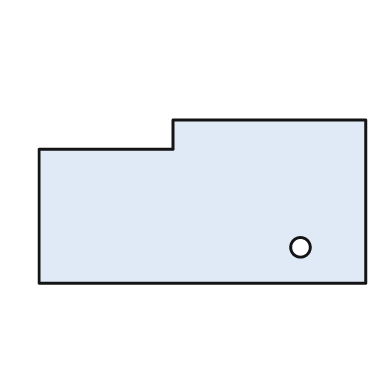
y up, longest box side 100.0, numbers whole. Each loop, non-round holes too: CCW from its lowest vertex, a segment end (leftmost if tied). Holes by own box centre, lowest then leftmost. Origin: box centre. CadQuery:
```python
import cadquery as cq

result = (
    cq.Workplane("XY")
    .moveTo(-50.0, -25.0)
    .lineTo(50.0, -25.0)
    .lineTo(50.0, 25.0)
    .lineTo(-9.0, 25.0)
    .lineTo(-9.0, 16.0)
    .lineTo(-50.0, 16.0)
    .close()
    .moveTo(30.0, -14.0)
    .circle(3.0)
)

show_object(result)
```